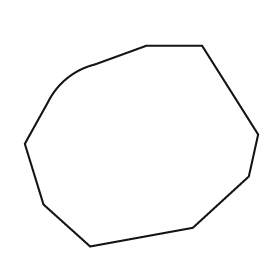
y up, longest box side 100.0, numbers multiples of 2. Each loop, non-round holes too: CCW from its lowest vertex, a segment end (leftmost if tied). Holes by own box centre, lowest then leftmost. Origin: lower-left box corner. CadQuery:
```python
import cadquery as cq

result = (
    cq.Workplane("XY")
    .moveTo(28.0, 0.0)
    .lineTo(72.0, 8.0)
    .lineTo(96.0, 30.0)
    .lineTo(100.0, 48.0)
    .lineTo(76.0, 86.0)
    .lineTo(52.0, 86.0)
    .lineTo(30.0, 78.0)
    .threePointArc((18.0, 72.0), (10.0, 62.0))
    .lineTo(0.0, 44.0)
    .lineTo(8.0, 18.0)
    .close()
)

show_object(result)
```